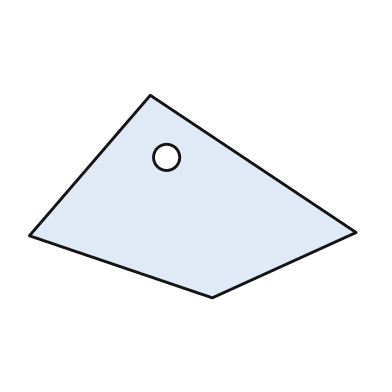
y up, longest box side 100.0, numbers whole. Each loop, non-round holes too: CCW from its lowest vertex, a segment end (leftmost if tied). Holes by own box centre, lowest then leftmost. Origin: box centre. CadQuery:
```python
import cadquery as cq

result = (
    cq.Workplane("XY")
    .moveTo(6.0, -31.0)
    .lineTo(50.0, -11.0)
    .lineTo(-13.0, 31.0)
    .lineTo(-50.0, -12.0)
    .close()
    .moveTo(-8.0, 12.0)
    .circle(4.0)
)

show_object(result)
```